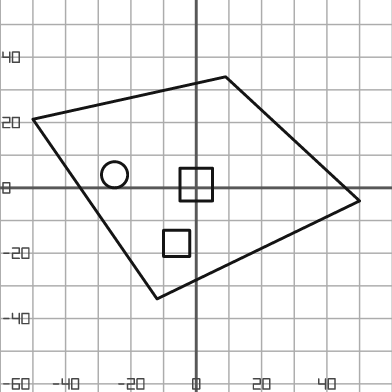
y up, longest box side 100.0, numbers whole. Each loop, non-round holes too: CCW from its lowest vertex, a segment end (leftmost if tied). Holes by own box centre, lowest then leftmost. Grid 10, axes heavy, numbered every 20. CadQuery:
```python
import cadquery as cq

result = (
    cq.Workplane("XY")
    .moveTo(-12.0, -34.0)
    .lineTo(50.0, -4.0)
    .lineTo(9.0, 34.0)
    .lineTo(-50.0, 21.0)
    .close()
    .moveTo(-10.0, -21.0)
    .lineTo(-2.0, -21.0)
    .lineTo(-2.0, -13.0)
    .lineTo(-10.0, -13.0)
    .close()
    .moveTo(-5.0, -4.0)
    .lineTo(5.0, -4.0)
    .lineTo(5.0, 6.0)
    .lineTo(-5.0, 6.0)
    .close()
    .moveTo(-25.0, 4.0)
    .circle(4.0)
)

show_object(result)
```